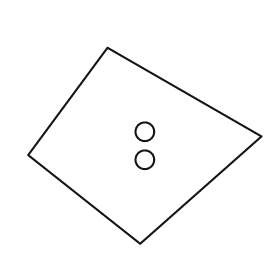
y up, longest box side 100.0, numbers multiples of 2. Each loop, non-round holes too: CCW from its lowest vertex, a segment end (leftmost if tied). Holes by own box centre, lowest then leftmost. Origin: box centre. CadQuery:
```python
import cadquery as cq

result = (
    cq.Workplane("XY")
    .moveTo(-2.0, -42.0)
    .lineTo(50.0, 4.0)
    .lineTo(-16.0, 42.0)
    .lineTo(-50.0, -4.0)
    .close()
    .moveTo(0.0, -6.0)
    .circle(4.0)
    .moveTo(0.0, 6.0)
    .circle(4.0)
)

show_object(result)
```